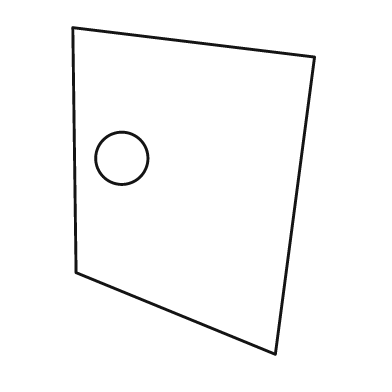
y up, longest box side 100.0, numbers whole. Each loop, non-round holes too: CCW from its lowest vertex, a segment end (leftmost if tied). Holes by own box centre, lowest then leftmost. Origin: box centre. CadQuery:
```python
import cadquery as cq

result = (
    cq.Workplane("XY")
    .moveTo(25.0, -50.0)
    .lineTo(37.0, 41.0)
    .lineTo(-37.0, 50.0)
    .lineTo(-36.0, -25.0)
    .close()
    .moveTo(-22.0, 10.0)
    .circle(8.0)
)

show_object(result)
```